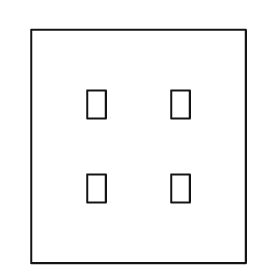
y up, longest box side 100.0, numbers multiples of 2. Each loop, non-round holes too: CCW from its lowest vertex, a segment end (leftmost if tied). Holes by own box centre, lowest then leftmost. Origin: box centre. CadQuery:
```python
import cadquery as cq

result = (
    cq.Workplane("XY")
    .moveTo(-46.0, -50.0)
    .lineTo(46.0, -50.0)
    .lineTo(46.0, 50.0)
    .lineTo(-46.0, 50.0)
    .close()
    .moveTo(-22.0, -24.0)
    .lineTo(-14.0, -24.0)
    .lineTo(-14.0, -12.0)
    .lineTo(-22.0, -12.0)
    .close()
    .moveTo(14.0, -24.0)
    .lineTo(22.0, -24.0)
    .lineTo(22.0, -12.0)
    .lineTo(14.0, -12.0)
    .close()
    .moveTo(-22.0, 12.0)
    .lineTo(-14.0, 12.0)
    .lineTo(-14.0, 24.0)
    .lineTo(-22.0, 24.0)
    .close()
    .moveTo(14.0, 12.0)
    .lineTo(22.0, 12.0)
    .lineTo(22.0, 24.0)
    .lineTo(14.0, 24.0)
    .close()
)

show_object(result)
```